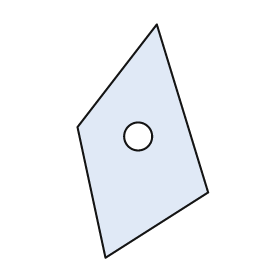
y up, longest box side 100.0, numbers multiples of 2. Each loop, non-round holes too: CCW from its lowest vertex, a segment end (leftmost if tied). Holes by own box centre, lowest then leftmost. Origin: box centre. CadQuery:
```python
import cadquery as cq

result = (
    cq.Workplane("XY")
    .moveTo(-16.0, -50.0)
    .lineTo(28.0, -22.0)
    .lineTo(6.0, 50.0)
    .lineTo(-28.0, 6.0)
    .close()
    .moveTo(-2.0, 2.0)
    .circle(6.0)
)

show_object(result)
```